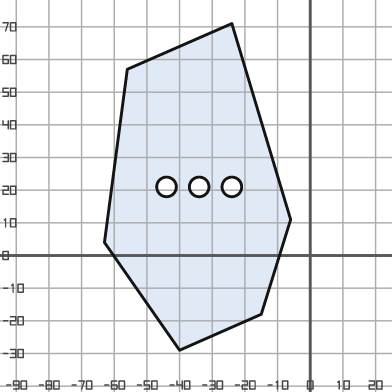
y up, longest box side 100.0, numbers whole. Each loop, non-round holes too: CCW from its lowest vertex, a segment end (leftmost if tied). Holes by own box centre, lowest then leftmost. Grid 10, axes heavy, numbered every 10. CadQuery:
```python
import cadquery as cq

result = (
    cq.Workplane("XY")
    .moveTo(-40.0, -29.0)
    .lineTo(-15.0, -18.0)
    .lineTo(-6.0, 11.0)
    .lineTo(-24.0, 71.0)
    .lineTo(-56.0, 57.0)
    .lineTo(-63.0, 4.0)
    .close()
    .moveTo(-44.0, 21.0)
    .circle(3.0)
    .moveTo(-34.0, 21.0)
    .circle(3.0)
    .moveTo(-24.0, 21.0)
    .circle(3.0)
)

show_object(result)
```